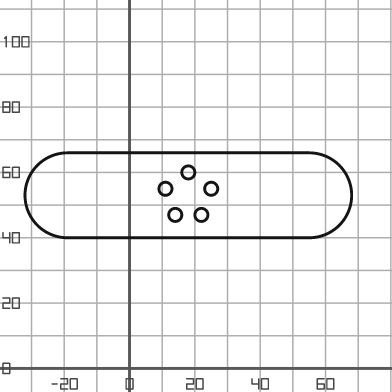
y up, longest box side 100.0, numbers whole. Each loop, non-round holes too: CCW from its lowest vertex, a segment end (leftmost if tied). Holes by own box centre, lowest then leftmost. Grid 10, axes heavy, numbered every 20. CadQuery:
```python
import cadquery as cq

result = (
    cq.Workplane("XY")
    .moveTo(-19.0, 40.0)
    .lineTo(55.0, 40.0)
    .threePointArc((68.0, 53.0), (55.0, 66.0))
    .lineTo(-19.0, 66.0)
    .threePointArc((-32.0, 53.0), (-19.0, 40.0))
    .close()
    .moveTo(14.0, 47.0)
    .circle(2.0)
    .moveTo(22.0, 47.0)
    .circle(2.0)
    .moveTo(11.0, 55.0)
    .circle(2.0)
    .moveTo(25.0, 55.0)
    .circle(2.0)
    .moveTo(18.0, 60.0)
    .circle(2.0)
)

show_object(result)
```